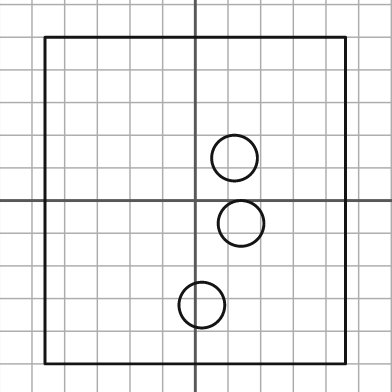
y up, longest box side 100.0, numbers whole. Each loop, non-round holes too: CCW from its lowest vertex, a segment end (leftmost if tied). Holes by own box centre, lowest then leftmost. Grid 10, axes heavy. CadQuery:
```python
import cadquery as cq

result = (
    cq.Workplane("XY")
    .moveTo(-46.0, -50.0)
    .lineTo(46.0, -50.0)
    .lineTo(46.0, 50.0)
    .lineTo(-46.0, 50.0)
    .close()
    .moveTo(2.0, -32.0)
    .circle(7.0)
    .moveTo(14.0, -7.0)
    .circle(7.0)
    .moveTo(12.0, 13.0)
    .circle(7.0)
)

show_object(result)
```